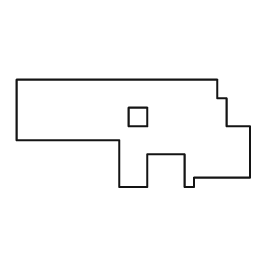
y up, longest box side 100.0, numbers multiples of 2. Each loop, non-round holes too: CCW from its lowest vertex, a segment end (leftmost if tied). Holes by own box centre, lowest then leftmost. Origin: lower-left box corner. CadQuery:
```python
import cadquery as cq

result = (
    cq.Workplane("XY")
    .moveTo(44.0, 0.0)
    .lineTo(56.0, 0.0)
    .lineTo(56.0, 14.0)
    .lineTo(72.0, 14.0)
    .lineTo(72.0, 0.0)
    .lineTo(76.0, 0.0)
    .lineTo(76.0, 4.0)
    .lineTo(100.0, 4.0)
    .lineTo(100.0, 26.0)
    .lineTo(90.0, 26.0)
    .lineTo(90.0, 38.0)
    .lineTo(86.0, 38.0)
    .lineTo(86.0, 46.0)
    .lineTo(0.0, 46.0)
    .lineTo(0.0, 20.0)
    .lineTo(44.0, 20.0)
    .close()
    .moveTo(48.0, 26.0)
    .lineTo(56.0, 26.0)
    .lineTo(56.0, 34.0)
    .lineTo(48.0, 34.0)
    .close()
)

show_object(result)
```